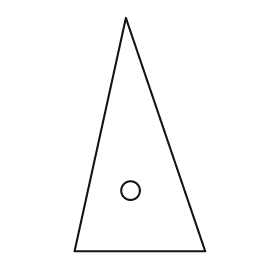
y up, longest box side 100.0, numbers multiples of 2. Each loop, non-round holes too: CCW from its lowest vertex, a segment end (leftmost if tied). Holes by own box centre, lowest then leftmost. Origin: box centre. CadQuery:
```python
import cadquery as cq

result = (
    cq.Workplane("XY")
    .moveTo(-28.0, -50.0)
    .lineTo(28.0, -50.0)
    .lineTo(-6.0, 50.0)
    .close()
    .moveTo(-4.0, -24.0)
    .circle(4.0)
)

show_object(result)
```